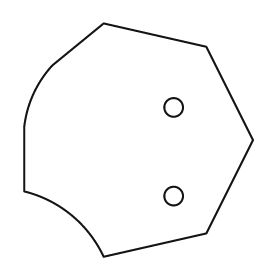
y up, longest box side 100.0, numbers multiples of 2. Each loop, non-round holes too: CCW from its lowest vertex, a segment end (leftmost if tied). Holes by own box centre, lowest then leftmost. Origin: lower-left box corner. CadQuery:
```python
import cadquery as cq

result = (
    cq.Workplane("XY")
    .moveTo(34.0, 0.0)
    .lineTo(78.0, 10.0)
    .lineTo(98.0, 50.0)
    .lineTo(78.0, 90.0)
    .lineTo(34.0, 100.0)
    .lineTo(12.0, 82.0)
    .threePointArc((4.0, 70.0), (0.0, 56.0))
    .lineTo(0.0, 28.0)
    .threePointArc((20.0, 18.0), (34.0, 0.0))
    .close()
    .moveTo(64.0, 26.0)
    .circle(4.0)
    .moveTo(64.0, 64.0)
    .circle(4.0)
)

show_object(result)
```